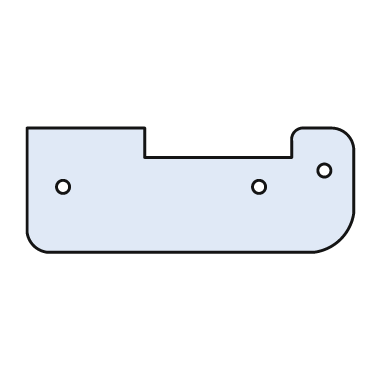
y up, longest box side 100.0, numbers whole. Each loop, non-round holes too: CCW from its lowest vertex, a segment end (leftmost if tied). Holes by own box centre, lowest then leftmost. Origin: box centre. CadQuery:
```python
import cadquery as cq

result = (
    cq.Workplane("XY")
    .moveTo(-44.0, -19.0)
    .lineTo(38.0, -19.0)
    .threePointArc((46.0, -15.0), (50.0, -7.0))
    .lineTo(50.0, 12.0)
    .threePointArc((48.0, 17.0), (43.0, 19.0))
    .lineTo(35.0, 19.0)
    .threePointArc((32.0, 18.0), (31.0, 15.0))
    .lineTo(31.0, 10.0)
    .lineTo(-14.0, 10.0)
    .lineTo(-14.0, 19.0)
    .lineTo(-50.0, 19.0)
    .lineTo(-50.0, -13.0)
    .threePointArc((-48.0, -17.0), (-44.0, -19.0))
    .close()
    .moveTo(-39.0, 1.0)
    .circle(2.0)
    .moveTo(21.0, 1.0)
    .circle(2.0)
    .moveTo(41.0, 6.0)
    .circle(2.0)
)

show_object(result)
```